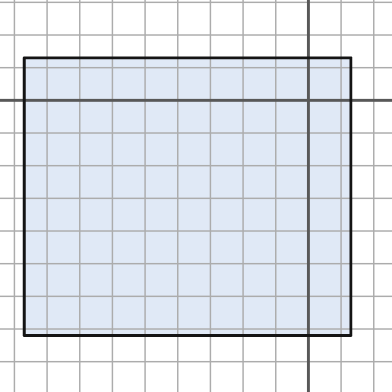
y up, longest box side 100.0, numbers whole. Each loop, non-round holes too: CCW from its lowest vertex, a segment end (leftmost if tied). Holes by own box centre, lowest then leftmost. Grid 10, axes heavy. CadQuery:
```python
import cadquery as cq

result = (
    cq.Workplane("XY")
    .moveTo(-87.0, -72.0)
    .lineTo(13.0, -72.0)
    .lineTo(13.0, 13.0)
    .lineTo(-87.0, 13.0)
    .close()
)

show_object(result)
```